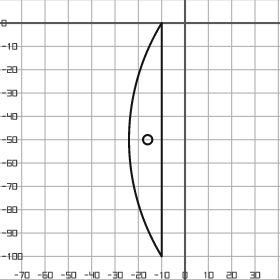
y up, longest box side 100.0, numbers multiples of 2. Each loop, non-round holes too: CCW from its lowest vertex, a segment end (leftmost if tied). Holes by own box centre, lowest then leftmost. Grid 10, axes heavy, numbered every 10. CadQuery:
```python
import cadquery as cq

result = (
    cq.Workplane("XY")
    .moveTo(-10.0, -100.0)
    .lineTo(-10.0, 0.0)
    .threePointArc((-24.0, -50.0), (-10.0, -100.0))
    .close()
    .moveTo(-16.0, -50.0)
    .circle(2.0)
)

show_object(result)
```